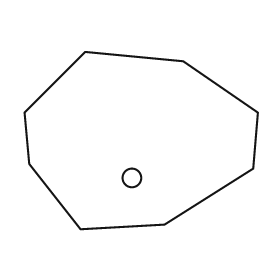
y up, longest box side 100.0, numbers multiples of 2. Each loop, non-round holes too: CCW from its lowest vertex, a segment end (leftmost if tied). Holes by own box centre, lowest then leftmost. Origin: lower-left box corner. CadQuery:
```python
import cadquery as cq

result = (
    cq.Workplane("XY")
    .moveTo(24.0, 0.0)
    .lineTo(60.0, 2.0)
    .lineTo(98.0, 26.0)
    .lineTo(100.0, 50.0)
    .lineTo(68.0, 72.0)
    .lineTo(26.0, 76.0)
    .lineTo(0.0, 50.0)
    .lineTo(2.0, 28.0)
    .close()
    .moveTo(46.0, 22.0)
    .circle(4.0)
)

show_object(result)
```